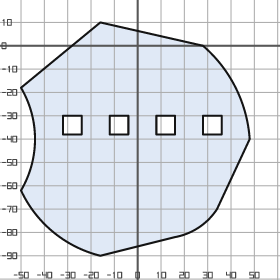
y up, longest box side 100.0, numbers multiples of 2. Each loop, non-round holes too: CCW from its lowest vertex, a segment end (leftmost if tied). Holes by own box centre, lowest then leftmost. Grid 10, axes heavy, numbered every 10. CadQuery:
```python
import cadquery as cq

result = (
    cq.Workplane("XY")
    .moveTo(-16.0, -90.0)
    .lineTo(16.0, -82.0)
    .threePointArc((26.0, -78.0), (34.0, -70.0))
    .lineTo(48.0, -40.0)
    .threePointArc((42.0, -18.0), (28.0, 0.0))
    .lineTo(-16.0, 10.0)
    .lineTo(-50.0, -18.0)
    .threePointArc((-44.0, -40.0), (-50.0, -62.0))
    .threePointArc((-36.0, -80.0), (-16.0, -90.0))
    .close()
    .moveTo(-32.0, -38.0)
    .lineTo(-24.0, -38.0)
    .lineTo(-24.0, -30.0)
    .lineTo(-32.0, -30.0)
    .close()
    .moveTo(-12.0, -38.0)
    .lineTo(-4.0, -38.0)
    .lineTo(-4.0, -30.0)
    .lineTo(-12.0, -30.0)
    .close()
    .moveTo(8.0, -38.0)
    .lineTo(16.0, -38.0)
    .lineTo(16.0, -30.0)
    .lineTo(8.0, -30.0)
    .close()
    .moveTo(28.0, -38.0)
    .lineTo(36.0, -38.0)
    .lineTo(36.0, -30.0)
    .lineTo(28.0, -30.0)
    .close()
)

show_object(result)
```